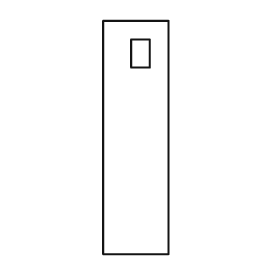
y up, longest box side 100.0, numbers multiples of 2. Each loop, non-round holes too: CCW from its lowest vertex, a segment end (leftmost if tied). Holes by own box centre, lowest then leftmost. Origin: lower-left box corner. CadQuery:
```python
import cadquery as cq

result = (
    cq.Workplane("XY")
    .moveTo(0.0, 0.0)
    .lineTo(28.0, 0.0)
    .lineTo(28.0, 100.0)
    .lineTo(0.0, 100.0)
    .close()
    .moveTo(12.0, 80.0)
    .lineTo(20.0, 80.0)
    .lineTo(20.0, 92.0)
    .lineTo(12.0, 92.0)
    .close()
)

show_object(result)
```